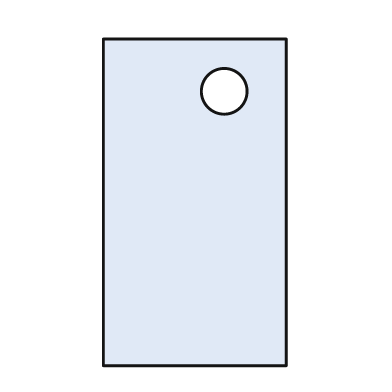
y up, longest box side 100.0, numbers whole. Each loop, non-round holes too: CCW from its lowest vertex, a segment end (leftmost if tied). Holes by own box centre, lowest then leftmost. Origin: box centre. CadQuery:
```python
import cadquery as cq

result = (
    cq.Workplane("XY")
    .moveTo(-28.0, -50.0)
    .lineTo(28.0, -50.0)
    .lineTo(28.0, 50.0)
    .lineTo(-28.0, 50.0)
    .close()
    .moveTo(9.0, 34.0)
    .circle(7.0)
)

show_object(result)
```